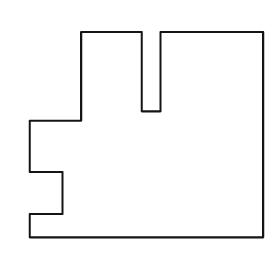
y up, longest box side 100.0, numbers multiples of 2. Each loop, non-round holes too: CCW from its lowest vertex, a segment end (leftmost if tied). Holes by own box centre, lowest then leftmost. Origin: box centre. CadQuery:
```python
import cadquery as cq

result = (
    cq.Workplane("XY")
    .moveTo(-50.0, -44.0)
    .lineTo(50.0, -44.0)
    .lineTo(50.0, 44.0)
    .lineTo(6.0, 44.0)
    .lineTo(6.0, 10.0)
    .lineTo(-2.0, 10.0)
    .lineTo(-2.0, 44.0)
    .lineTo(-28.0, 44.0)
    .lineTo(-28.0, 6.0)
    .lineTo(-50.0, 6.0)
    .lineTo(-50.0, -16.0)
    .lineTo(-36.0, -16.0)
    .lineTo(-36.0, -34.0)
    .lineTo(-50.0, -34.0)
    .close()
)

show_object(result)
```